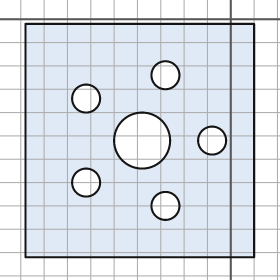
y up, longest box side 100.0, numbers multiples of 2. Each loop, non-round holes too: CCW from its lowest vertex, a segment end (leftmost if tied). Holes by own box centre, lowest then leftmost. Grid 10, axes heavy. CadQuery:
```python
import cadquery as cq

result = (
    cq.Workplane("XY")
    .moveTo(-88.0, -102.0)
    .lineTo(10.0, -102.0)
    .lineTo(10.0, -2.0)
    .lineTo(-88.0, -2.0)
    .close()
    .moveTo(-28.0, -80.0)
    .circle(6.0)
    .moveTo(-62.0, -70.0)
    .circle(6.0)
    .moveTo(-38.0, -52.0)
    .circle(12.0)
    .moveTo(-8.0, -52.0)
    .circle(6.0)
    .moveTo(-62.0, -34.0)
    .circle(6.0)
    .moveTo(-28.0, -24.0)
    .circle(6.0)
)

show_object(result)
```